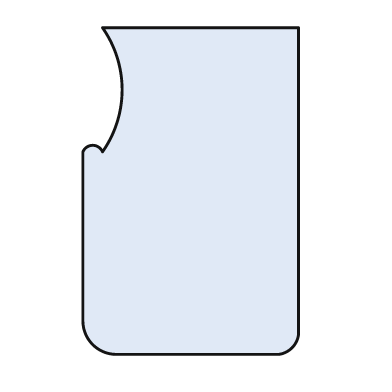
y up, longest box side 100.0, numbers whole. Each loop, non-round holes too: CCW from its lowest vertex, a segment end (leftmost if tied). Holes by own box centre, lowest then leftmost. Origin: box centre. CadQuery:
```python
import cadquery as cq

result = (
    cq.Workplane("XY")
    .moveTo(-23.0, -50.0)
    .lineTo(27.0, -50.0)
    .threePointArc((31.0, -48.0), (33.0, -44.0))
    .lineTo(33.0, 50.0)
    .lineTo(-27.0, 50.0)
    .threePointArc((-21.0, 31.0), (-27.0, 12.0))
    .threePointArc((-30.0, 14.0), (-33.0, 12.0))
    .lineTo(-33.0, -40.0)
    .threePointArc((-30.0, -47.0), (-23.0, -50.0))
    .close()
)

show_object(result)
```